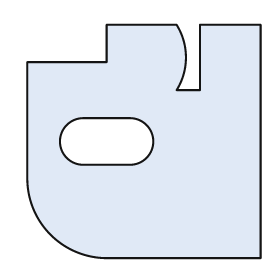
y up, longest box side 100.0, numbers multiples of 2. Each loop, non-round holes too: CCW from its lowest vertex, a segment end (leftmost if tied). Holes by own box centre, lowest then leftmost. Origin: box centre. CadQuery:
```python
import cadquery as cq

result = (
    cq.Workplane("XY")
    .moveTo(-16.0, -50.0)
    .lineTo(50.0, -50.0)
    .lineTo(50.0, 50.0)
    .lineTo(24.0, 50.0)
    .lineTo(24.0, 22.0)
    .lineTo(14.0, 22.0)
    .threePointArc((18.0, 36.0), (14.0, 50.0))
    .lineTo(-16.0, 50.0)
    .lineTo(-16.0, 34.0)
    .lineTo(-50.0, 34.0)
    .lineTo(-50.0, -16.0)
    .threePointArc((-40.0, -40.0), (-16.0, -50.0))
    .close()
    .moveTo(-26.0, -10.0)
    .lineTo(-6.0, -10.0)
    .threePointArc((4.0, 0.0), (-6.0, 10.0))
    .lineTo(-26.0, 10.0)
    .threePointArc((-36.0, 0.0), (-26.0, -10.0))
    .close()
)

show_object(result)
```